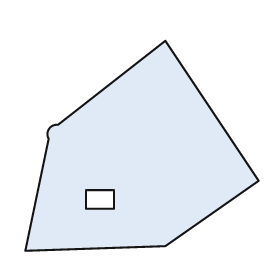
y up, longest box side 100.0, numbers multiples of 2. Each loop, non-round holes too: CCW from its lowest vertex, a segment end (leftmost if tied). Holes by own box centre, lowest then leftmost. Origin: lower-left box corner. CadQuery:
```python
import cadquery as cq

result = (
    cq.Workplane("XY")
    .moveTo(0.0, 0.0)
    .lineTo(60.0, 2.0)
    .lineTo(100.0, 30.0)
    .lineTo(60.0, 90.0)
    .lineTo(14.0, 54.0)
    .threePointArc((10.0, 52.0), (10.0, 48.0))
    .close()
    .moveTo(26.0, 18.0)
    .lineTo(38.0, 18.0)
    .lineTo(38.0, 26.0)
    .lineTo(26.0, 26.0)
    .close()
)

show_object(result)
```